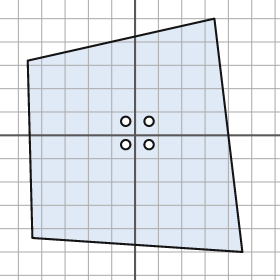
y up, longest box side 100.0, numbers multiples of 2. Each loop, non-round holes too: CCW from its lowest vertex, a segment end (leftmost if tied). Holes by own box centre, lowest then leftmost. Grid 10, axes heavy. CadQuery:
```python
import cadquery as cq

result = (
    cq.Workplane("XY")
    .moveTo(46.0, -50.0)
    .lineTo(34.0, 50.0)
    .lineTo(-46.0, 32.0)
    .lineTo(-44.0, -44.0)
    .close()
    .moveTo(-4.0, -4.0)
    .circle(2.0)
    .moveTo(6.0, -4.0)
    .circle(2.0)
    .moveTo(-4.0, 6.0)
    .circle(2.0)
    .moveTo(6.0, 6.0)
    .circle(2.0)
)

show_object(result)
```